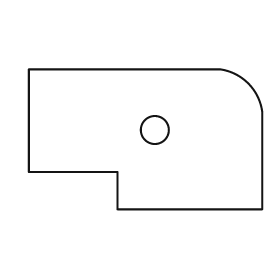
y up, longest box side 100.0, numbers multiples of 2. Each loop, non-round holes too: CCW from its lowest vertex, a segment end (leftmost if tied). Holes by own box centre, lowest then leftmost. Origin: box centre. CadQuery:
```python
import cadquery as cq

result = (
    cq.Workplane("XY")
    .moveTo(-12.0, -30.0)
    .lineTo(50.0, -30.0)
    .lineTo(50.0, 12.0)
    .threePointArc((44.0, 24.0), (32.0, 30.0))
    .lineTo(-50.0, 30.0)
    .lineTo(-50.0, -14.0)
    .lineTo(-12.0, -14.0)
    .close()
    .moveTo(4.0, 4.0)
    .circle(6.0)
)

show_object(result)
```